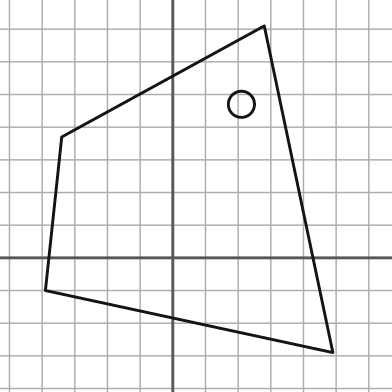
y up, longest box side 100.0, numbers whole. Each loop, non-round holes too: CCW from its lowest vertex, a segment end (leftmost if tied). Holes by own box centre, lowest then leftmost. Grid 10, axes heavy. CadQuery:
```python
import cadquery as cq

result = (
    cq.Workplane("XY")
    .moveTo(49.0, -29.0)
    .lineTo(28.0, 71.0)
    .lineTo(-34.0, 37.0)
    .lineTo(-39.0, -10.0)
    .close()
    .moveTo(21.0, 47.0)
    .circle(4.0)
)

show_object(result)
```